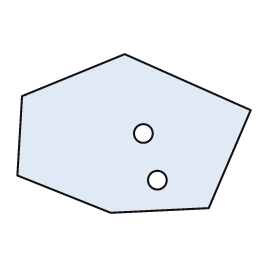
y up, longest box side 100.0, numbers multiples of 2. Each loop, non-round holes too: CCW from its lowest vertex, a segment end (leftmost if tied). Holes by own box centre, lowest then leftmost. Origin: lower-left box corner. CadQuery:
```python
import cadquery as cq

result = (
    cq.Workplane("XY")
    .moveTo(40.0, 0.0)
    .lineTo(82.0, 2.0)
    .lineTo(100.0, 44.0)
    .lineTo(46.0, 68.0)
    .lineTo(2.0, 50.0)
    .lineTo(0.0, 16.0)
    .close()
    .moveTo(60.0, 14.0)
    .circle(4.0)
    .moveTo(54.0, 34.0)
    .circle(4.0)
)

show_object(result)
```